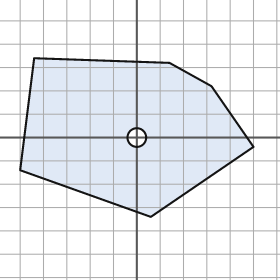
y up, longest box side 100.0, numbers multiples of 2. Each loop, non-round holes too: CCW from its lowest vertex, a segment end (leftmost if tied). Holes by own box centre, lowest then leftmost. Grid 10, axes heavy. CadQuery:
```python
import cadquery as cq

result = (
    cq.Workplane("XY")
    .moveTo(6.0, -34.0)
    .lineTo(50.0, -4.0)
    .lineTo(32.0, 22.0)
    .lineTo(14.0, 32.0)
    .lineTo(-44.0, 34.0)
    .lineTo(-50.0, -14.0)
    .close()
    .moveTo(0.0, 0.0)
    .circle(4.0)
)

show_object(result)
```